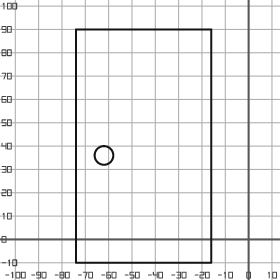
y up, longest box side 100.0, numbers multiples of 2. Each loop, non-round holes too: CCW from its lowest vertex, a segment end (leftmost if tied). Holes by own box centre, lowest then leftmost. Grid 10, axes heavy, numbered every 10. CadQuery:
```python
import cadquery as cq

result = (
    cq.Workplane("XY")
    .moveTo(-74.0, -10.0)
    .lineTo(-16.0, -10.0)
    .lineTo(-16.0, 90.0)
    .lineTo(-74.0, 90.0)
    .close()
    .moveTo(-62.0, 36.0)
    .circle(4.0)
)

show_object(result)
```